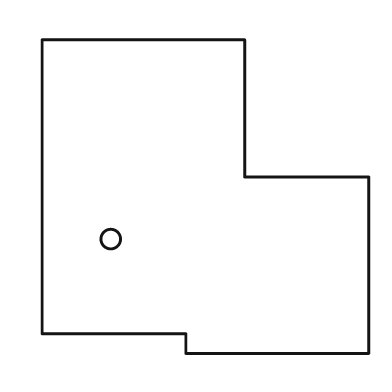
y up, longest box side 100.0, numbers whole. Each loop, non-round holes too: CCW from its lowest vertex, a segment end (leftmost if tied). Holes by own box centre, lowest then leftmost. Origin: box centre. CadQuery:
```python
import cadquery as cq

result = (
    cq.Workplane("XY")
    .moveTo(-6.0, -48.0)
    .lineTo(50.0, -48.0)
    .lineTo(50.0, 6.0)
    .lineTo(12.0, 6.0)
    .lineTo(12.0, 48.0)
    .lineTo(-50.0, 48.0)
    .lineTo(-50.0, -42.0)
    .lineTo(-6.0, -42.0)
    .close()
    .moveTo(-29.0, -13.0)
    .circle(3.0)
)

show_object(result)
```